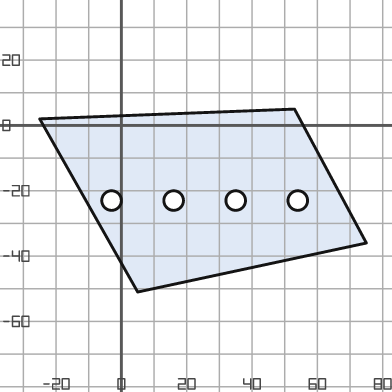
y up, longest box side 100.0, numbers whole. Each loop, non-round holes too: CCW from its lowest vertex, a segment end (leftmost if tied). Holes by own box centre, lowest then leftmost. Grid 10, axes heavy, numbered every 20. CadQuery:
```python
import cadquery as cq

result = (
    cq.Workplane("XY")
    .moveTo(5.0, -51.0)
    .lineTo(75.0, -36.0)
    .lineTo(53.0, 5.0)
    .lineTo(-25.0, 2.0)
    .close()
    .moveTo(-3.0, -23.0)
    .circle(3.0)
    .moveTo(16.0, -23.0)
    .circle(3.0)
    .moveTo(35.0, -23.0)
    .circle(3.0)
    .moveTo(54.0, -23.0)
    .circle(3.0)
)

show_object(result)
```